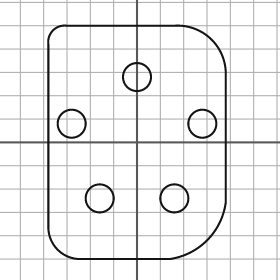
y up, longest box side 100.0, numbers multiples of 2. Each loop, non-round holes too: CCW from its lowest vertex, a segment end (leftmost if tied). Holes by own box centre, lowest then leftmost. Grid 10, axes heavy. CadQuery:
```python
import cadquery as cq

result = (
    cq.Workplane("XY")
    .moveTo(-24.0, -50.0)
    .lineTo(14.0, -50.0)
    .threePointArc((30.0, -42.0), (38.0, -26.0))
    .lineTo(38.0, 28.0)
    .threePointArc((32.0, 44.0), (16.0, 50.0))
    .lineTo(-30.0, 50.0)
    .threePointArc((-36.0, 48.0), (-38.0, 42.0))
    .lineTo(-38.0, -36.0)
    .threePointArc((-34.0, -46.0), (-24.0, -50.0))
    .close()
    .moveTo(-16.0, -24.0)
    .circle(6.0)
    .moveTo(16.0, -24.0)
    .circle(6.0)
    .moveTo(-28.0, 8.0)
    .circle(6.0)
    .moveTo(28.0, 8.0)
    .circle(6.0)
    .moveTo(0.0, 28.0)
    .circle(6.0)
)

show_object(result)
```